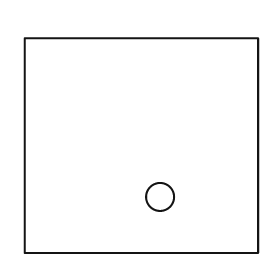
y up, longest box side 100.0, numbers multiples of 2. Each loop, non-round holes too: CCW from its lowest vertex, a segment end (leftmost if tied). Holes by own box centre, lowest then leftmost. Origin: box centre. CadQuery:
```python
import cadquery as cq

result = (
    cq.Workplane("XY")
    .moveTo(-50.0, -46.0)
    .lineTo(50.0, -46.0)
    .lineTo(50.0, 46.0)
    .lineTo(-50.0, 46.0)
    .close()
    .moveTo(8.0, -22.0)
    .circle(6.0)
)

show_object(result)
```